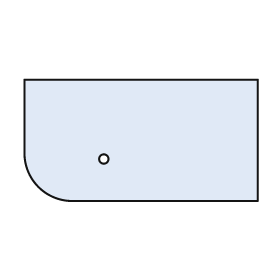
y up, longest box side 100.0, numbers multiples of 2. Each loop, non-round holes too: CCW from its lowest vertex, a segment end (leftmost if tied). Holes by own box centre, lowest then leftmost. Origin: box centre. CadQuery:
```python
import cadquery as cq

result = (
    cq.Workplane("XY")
    .moveTo(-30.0, -26.0)
    .lineTo(50.0, -26.0)
    .lineTo(50.0, 26.0)
    .lineTo(-50.0, 26.0)
    .lineTo(-50.0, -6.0)
    .threePointArc((-44.0, -20.0), (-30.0, -26.0))
    .close()
    .moveTo(-16.0, -8.0)
    .circle(2.0)
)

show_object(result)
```